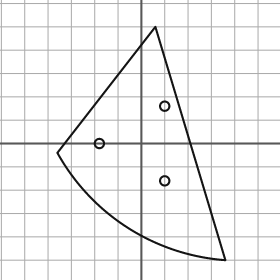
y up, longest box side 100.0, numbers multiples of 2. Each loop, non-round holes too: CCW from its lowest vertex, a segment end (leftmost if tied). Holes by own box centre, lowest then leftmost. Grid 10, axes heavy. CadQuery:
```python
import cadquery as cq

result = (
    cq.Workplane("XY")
    .moveTo(36.0, -50.0)
    .lineTo(6.0, 50.0)
    .lineTo(-36.0, -4.0)
    .threePointArc((-6.0, -36.0), (36.0, -50.0))
    .close()
    .moveTo(10.0, -16.0)
    .circle(2.0)
    .moveTo(-18.0, 0.0)
    .circle(2.0)
    .moveTo(10.0, 16.0)
    .circle(2.0)
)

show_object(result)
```